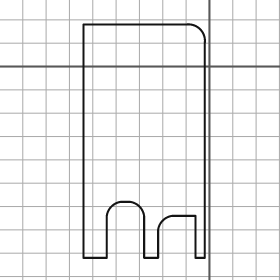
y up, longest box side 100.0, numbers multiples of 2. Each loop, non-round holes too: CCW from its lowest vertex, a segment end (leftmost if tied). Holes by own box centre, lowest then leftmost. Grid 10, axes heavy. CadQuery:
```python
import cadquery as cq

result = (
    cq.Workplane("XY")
    .moveTo(-54.0, -82.0)
    .lineTo(-44.0, -82.0)
    .lineTo(-44.0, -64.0)
    .threePointArc((-42.0, -60.0), (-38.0, -58.0))
    .lineTo(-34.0, -58.0)
    .threePointArc((-30.0, -60.0), (-28.0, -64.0))
    .lineTo(-28.0, -82.0)
    .lineTo(-22.0, -82.0)
    .lineTo(-22.0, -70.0)
    .threePointArc((-20.0, -66.0), (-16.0, -64.0))
    .lineTo(-6.0, -64.0)
    .lineTo(-6.0, -82.0)
    .lineTo(-2.0, -82.0)
    .lineTo(-2.0, 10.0)
    .threePointArc((-4.0, 16.0), (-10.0, 18.0))
    .lineTo(-54.0, 18.0)
    .close()
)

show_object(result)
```